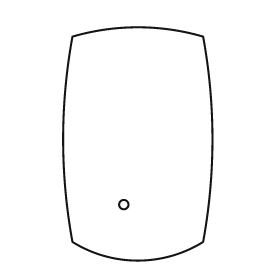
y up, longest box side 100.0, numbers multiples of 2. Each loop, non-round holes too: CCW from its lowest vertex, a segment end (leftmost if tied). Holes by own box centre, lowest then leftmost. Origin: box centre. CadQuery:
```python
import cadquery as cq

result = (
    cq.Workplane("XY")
    .moveTo(-28.0, -42.0)
    .threePointArc((0.0, -50.0), (28.0, -42.0))
    .threePointArc((32.0, 2.0), (28.0, 46.0))
    .threePointArc((0.0, 50.0), (-28.0, 46.0))
    .threePointArc((-32.0, 2.0), (-28.0, -42.0))
    .close()
    .moveTo(-6.0, -26.0)
    .circle(2.0)
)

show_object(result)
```